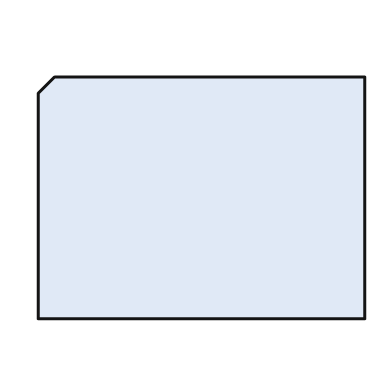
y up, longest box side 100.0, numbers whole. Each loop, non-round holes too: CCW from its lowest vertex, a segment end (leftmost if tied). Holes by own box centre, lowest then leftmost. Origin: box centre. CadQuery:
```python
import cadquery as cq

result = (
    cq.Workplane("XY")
    .moveTo(-50.0, -37.0)
    .lineTo(50.0, -37.0)
    .lineTo(50.0, 37.0)
    .lineTo(-45.0, 37.0)
    .lineTo(-50.0, 32.0)
    .close()
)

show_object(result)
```